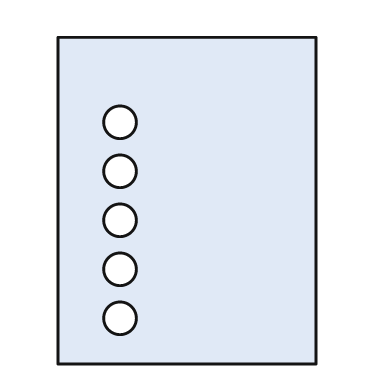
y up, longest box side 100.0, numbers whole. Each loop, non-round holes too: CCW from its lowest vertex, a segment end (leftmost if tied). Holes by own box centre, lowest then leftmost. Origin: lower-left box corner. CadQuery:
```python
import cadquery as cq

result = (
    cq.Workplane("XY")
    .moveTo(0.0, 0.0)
    .lineTo(79.0, 0.0)
    .lineTo(79.0, 100.0)
    .lineTo(0.0, 100.0)
    .close()
    .moveTo(19.0, 14.0)
    .circle(5.0)
    .moveTo(19.0, 29.0)
    .circle(5.0)
    .moveTo(19.0, 44.0)
    .circle(5.0)
    .moveTo(19.0, 59.0)
    .circle(5.0)
    .moveTo(19.0, 74.0)
    .circle(5.0)
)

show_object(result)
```